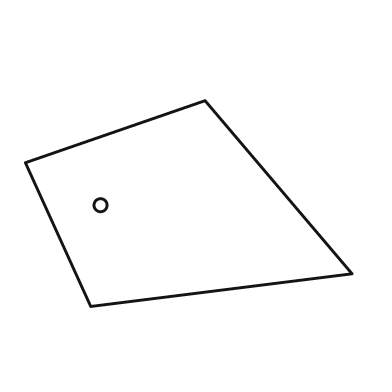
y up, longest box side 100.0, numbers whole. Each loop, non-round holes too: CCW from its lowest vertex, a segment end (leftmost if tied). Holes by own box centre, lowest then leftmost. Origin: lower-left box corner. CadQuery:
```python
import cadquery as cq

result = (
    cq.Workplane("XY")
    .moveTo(20.0, 0.0)
    .lineTo(100.0, 10.0)
    .lineTo(55.0, 63.0)
    .lineTo(0.0, 44.0)
    .close()
    .moveTo(23.0, 31.0)
    .circle(2.0)
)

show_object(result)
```